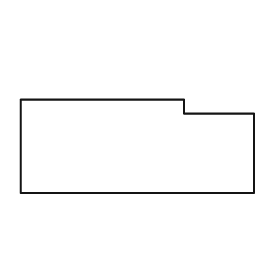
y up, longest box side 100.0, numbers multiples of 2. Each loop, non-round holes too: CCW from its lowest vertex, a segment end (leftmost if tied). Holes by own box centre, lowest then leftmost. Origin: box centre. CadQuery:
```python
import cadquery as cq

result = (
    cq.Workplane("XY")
    .moveTo(-50.0, -20.0)
    .lineTo(50.0, -20.0)
    .lineTo(50.0, 14.0)
    .lineTo(20.0, 14.0)
    .lineTo(20.0, 20.0)
    .lineTo(-50.0, 20.0)
    .close()
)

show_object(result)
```